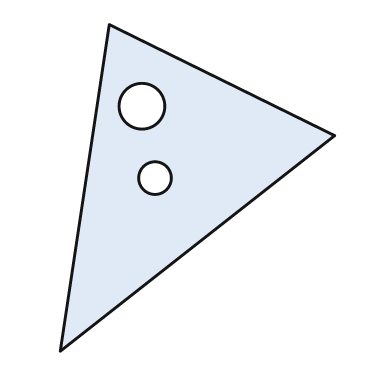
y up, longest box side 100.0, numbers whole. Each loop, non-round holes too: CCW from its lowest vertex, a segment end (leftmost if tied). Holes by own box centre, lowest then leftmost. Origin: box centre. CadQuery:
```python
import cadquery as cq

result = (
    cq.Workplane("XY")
    .moveTo(-42.0, -50.0)
    .lineTo(42.0, 16.0)
    .lineTo(-27.0, 50.0)
    .close()
    .moveTo(-13.0, 3.0)
    .circle(5.0)
    .moveTo(-17.0, 25.0)
    .circle(7.0)
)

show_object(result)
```